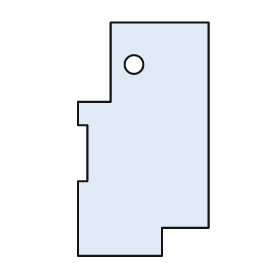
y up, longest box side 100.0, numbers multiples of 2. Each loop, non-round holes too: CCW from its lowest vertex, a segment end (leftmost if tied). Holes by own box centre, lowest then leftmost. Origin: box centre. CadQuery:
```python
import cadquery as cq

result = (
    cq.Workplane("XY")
    .moveTo(-28.0, -50.0)
    .lineTo(8.0, -50.0)
    .lineTo(8.0, -38.0)
    .lineTo(28.0, -38.0)
    .lineTo(28.0, 50.0)
    .lineTo(-14.0, 50.0)
    .lineTo(-14.0, 16.0)
    .lineTo(-28.0, 16.0)
    .lineTo(-28.0, 6.0)
    .lineTo(-24.0, 6.0)
    .lineTo(-24.0, -18.0)
    .lineTo(-28.0, -18.0)
    .close()
    .moveTo(-4.0, 32.0)
    .circle(4.0)
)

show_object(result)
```